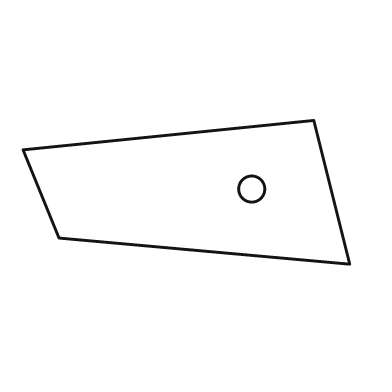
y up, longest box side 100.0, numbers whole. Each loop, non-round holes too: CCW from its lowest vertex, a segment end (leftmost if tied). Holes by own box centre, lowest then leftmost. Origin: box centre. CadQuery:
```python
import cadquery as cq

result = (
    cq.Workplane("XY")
    .moveTo(50.0, -22.0)
    .lineTo(39.0, 22.0)
    .lineTo(-50.0, 13.0)
    .lineTo(-39.0, -14.0)
    .close()
    .moveTo(20.0, 1.0)
    .circle(4.0)
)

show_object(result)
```